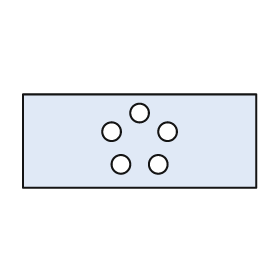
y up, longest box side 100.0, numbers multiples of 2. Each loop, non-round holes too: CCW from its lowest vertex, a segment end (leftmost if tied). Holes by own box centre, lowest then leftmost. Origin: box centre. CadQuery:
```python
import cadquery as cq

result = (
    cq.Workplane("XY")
    .moveTo(-50.0, -20.0)
    .lineTo(50.0, -20.0)
    .lineTo(50.0, 20.0)
    .lineTo(-50.0, 20.0)
    .close()
    .moveTo(-8.0, -10.0)
    .circle(4.0)
    .moveTo(8.0, -10.0)
    .circle(4.0)
    .moveTo(-12.0, 4.0)
    .circle(4.0)
    .moveTo(12.0, 4.0)
    .circle(4.0)
    .moveTo(0.0, 12.0)
    .circle(4.0)
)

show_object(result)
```